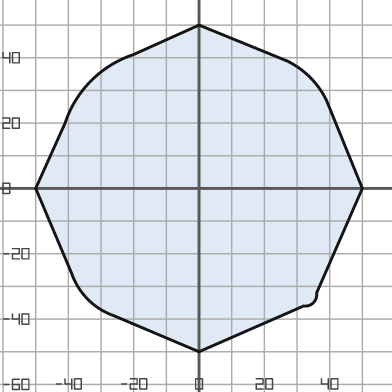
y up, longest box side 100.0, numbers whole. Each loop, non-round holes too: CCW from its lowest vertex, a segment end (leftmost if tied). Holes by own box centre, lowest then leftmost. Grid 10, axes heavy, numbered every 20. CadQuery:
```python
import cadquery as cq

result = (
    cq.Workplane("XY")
    .moveTo(0.0, -50.0)
    .lineTo(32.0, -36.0)
    .threePointArc((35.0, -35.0), (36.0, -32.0))
    .lineTo(50.0, 0.0)
    .lineTo(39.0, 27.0)
    .threePointArc((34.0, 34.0), (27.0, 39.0))
    .lineTo(0.0, 50.0)
    .lineTo(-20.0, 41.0)
    .threePointArc((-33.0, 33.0), (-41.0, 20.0))
    .lineTo(-50.0, 0.0)
    .lineTo(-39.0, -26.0)
    .threePointArc((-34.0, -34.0), (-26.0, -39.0))
    .close()
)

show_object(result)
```